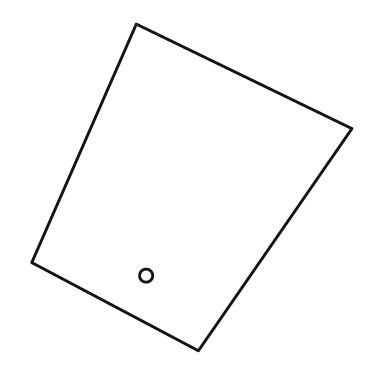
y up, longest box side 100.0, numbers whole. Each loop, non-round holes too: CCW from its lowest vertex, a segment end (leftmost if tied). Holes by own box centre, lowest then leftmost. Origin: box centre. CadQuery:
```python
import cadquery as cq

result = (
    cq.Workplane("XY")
    .moveTo(2.0, -50.0)
    .lineTo(49.0, 18.0)
    .lineTo(-17.0, 50.0)
    .lineTo(-49.0, -23.0)
    .close()
    .moveTo(-14.0, -27.0)
    .circle(2.0)
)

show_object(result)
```